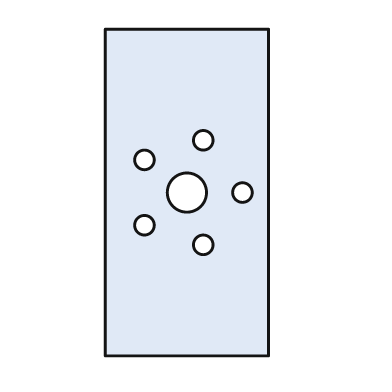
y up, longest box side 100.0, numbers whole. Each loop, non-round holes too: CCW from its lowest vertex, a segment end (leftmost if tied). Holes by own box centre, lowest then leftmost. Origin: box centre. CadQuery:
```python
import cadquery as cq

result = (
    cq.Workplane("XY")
    .moveTo(-25.0, -50.0)
    .lineTo(25.0, -50.0)
    .lineTo(25.0, 50.0)
    .lineTo(-25.0, 50.0)
    .close()
    .moveTo(5.0, -16.0)
    .circle(3.0)
    .moveTo(-13.0, -10.0)
    .circle(3.0)
    .moveTo(0.0, 0.0)
    .circle(6.0)
    .moveTo(17.0, 0.0)
    .circle(3.0)
    .moveTo(-13.0, 10.0)
    .circle(3.0)
    .moveTo(5.0, 16.0)
    .circle(3.0)
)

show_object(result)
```